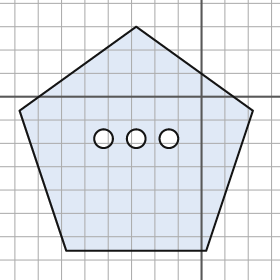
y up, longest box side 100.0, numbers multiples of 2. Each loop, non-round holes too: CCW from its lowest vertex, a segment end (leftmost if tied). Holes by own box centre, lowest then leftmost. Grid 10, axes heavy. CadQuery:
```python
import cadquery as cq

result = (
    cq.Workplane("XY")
    .moveTo(-58.0, -66.0)
    .lineTo(2.0, -66.0)
    .lineTo(22.0, -6.0)
    .lineTo(-28.0, 30.0)
    .lineTo(-78.0, -6.0)
    .close()
    .moveTo(-42.0, -18.0)
    .circle(4.0)
    .moveTo(-28.0, -18.0)
    .circle(4.0)
    .moveTo(-14.0, -18.0)
    .circle(4.0)
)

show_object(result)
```